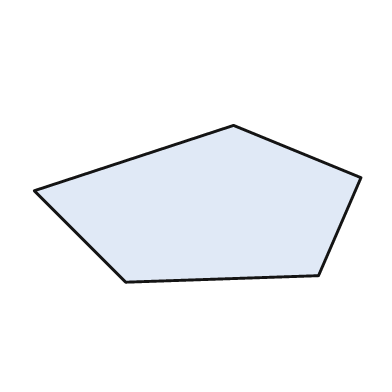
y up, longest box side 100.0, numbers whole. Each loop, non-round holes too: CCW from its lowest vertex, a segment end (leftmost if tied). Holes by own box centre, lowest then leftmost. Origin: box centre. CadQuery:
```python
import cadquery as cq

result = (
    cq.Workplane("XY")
    .moveTo(-22.0, -24.0)
    .lineTo(37.0, -22.0)
    .lineTo(50.0, 8.0)
    .lineTo(11.0, 24.0)
    .lineTo(-50.0, 4.0)
    .close()
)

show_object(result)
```